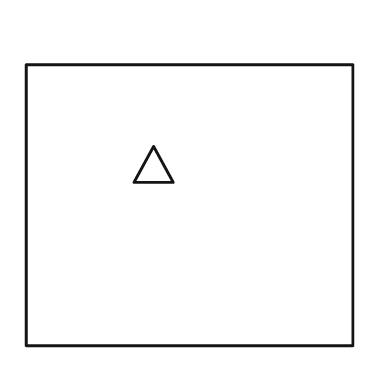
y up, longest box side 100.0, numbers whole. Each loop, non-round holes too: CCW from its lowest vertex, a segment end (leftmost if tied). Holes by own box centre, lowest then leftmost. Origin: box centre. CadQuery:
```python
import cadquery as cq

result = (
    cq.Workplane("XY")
    .moveTo(-50.0, -43.0)
    .lineTo(50.0, -43.0)
    .lineTo(50.0, 43.0)
    .lineTo(-50.0, 43.0)
    .close()
    .moveTo(-17.0, 7.0)
    .lineTo(-5.0, 7.0)
    .lineTo(-11.0, 18.0)
    .close()
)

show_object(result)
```